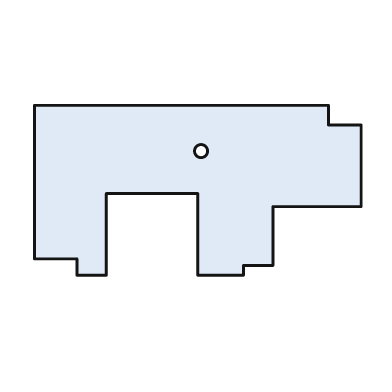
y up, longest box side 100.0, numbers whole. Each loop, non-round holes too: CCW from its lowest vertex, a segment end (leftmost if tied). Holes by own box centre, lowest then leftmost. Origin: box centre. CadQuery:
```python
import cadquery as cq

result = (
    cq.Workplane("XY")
    .moveTo(-37.0, -26.0)
    .lineTo(-28.0, -26.0)
    .lineTo(-28.0, -1.0)
    .lineTo(0.0, -1.0)
    .lineTo(0.0, -26.0)
    .lineTo(14.0, -26.0)
    .lineTo(14.0, -23.0)
    .lineTo(23.0, -23.0)
    .lineTo(23.0, -5.0)
    .lineTo(50.0, -5.0)
    .lineTo(50.0, 20.0)
    .lineTo(40.0, 20.0)
    .lineTo(40.0, 26.0)
    .lineTo(-50.0, 26.0)
    .lineTo(-50.0, -21.0)
    .lineTo(-37.0, -21.0)
    .close()
    .moveTo(1.0, 12.0)
    .circle(2.0)
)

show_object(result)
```